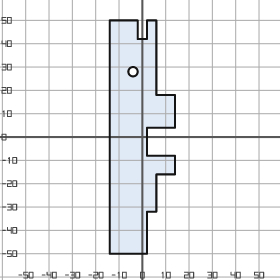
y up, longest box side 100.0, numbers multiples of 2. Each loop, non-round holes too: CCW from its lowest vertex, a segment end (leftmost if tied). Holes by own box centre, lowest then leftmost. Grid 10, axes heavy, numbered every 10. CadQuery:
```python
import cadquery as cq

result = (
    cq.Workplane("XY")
    .moveTo(-14.0, -50.0)
    .lineTo(2.0, -50.0)
    .lineTo(2.0, -32.0)
    .lineTo(6.0, -32.0)
    .lineTo(6.0, -16.0)
    .lineTo(14.0, -16.0)
    .lineTo(14.0, -8.0)
    .lineTo(2.0, -8.0)
    .lineTo(2.0, 4.0)
    .lineTo(14.0, 4.0)
    .lineTo(14.0, 18.0)
    .lineTo(6.0, 18.0)
    .lineTo(6.0, 50.0)
    .lineTo(2.0, 50.0)
    .lineTo(2.0, 42.0)
    .lineTo(-2.0, 42.0)
    .lineTo(-2.0, 50.0)
    .lineTo(-14.0, 50.0)
    .close()
    .moveTo(-4.0, 28.0)
    .circle(2.0)
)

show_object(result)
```